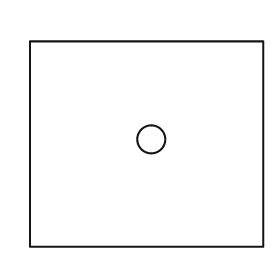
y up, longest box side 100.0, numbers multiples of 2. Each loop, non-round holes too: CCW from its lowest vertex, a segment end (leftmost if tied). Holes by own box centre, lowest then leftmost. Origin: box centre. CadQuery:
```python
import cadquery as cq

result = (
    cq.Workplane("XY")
    .moveTo(-50.0, -44.0)
    .lineTo(50.0, -44.0)
    .lineTo(50.0, 44.0)
    .lineTo(-50.0, 44.0)
    .close()
    .moveTo(2.0, 2.0)
    .circle(6.0)
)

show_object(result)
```